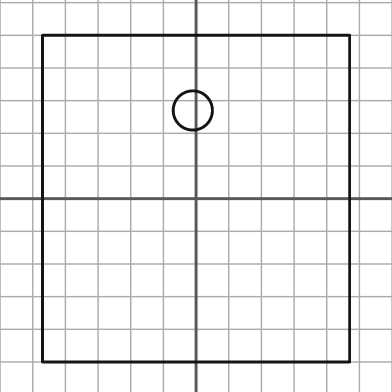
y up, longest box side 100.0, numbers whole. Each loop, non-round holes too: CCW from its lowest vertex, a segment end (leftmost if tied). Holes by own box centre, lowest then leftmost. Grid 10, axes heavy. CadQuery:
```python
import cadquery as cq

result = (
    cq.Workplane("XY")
    .moveTo(-47.0, -50.0)
    .lineTo(47.0, -50.0)
    .lineTo(47.0, 50.0)
    .lineTo(-47.0, 50.0)
    .close()
    .moveTo(-1.0, 27.0)
    .circle(6.0)
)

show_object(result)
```